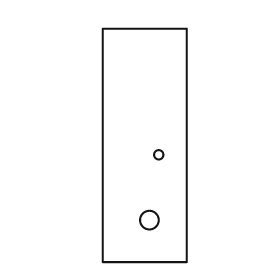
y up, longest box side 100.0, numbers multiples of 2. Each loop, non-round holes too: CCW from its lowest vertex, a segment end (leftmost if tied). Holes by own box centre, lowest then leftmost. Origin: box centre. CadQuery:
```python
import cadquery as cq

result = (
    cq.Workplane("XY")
    .moveTo(-18.0, -50.0)
    .lineTo(18.0, -50.0)
    .lineTo(18.0, 50.0)
    .lineTo(-18.0, 50.0)
    .close()
    .moveTo(2.0, -32.0)
    .circle(4.0)
    .moveTo(6.0, -4.0)
    .circle(2.0)
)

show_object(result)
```